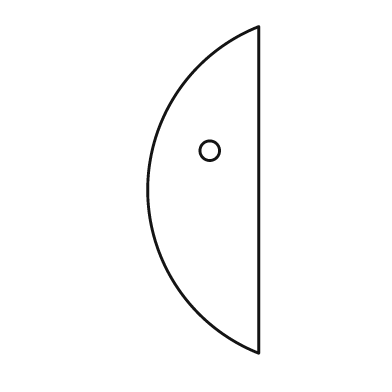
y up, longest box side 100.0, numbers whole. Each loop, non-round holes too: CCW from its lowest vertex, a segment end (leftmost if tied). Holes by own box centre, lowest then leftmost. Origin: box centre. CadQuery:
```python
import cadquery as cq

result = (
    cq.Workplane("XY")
    .moveTo(17.0, -50.0)
    .lineTo(17.0, 50.0)
    .threePointArc((-17.0, 0.0), (17.0, -50.0))
    .close()
    .moveTo(2.0, 12.0)
    .circle(3.0)
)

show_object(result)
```